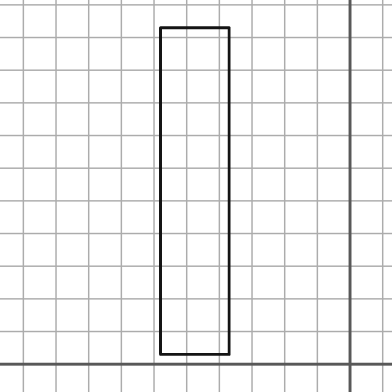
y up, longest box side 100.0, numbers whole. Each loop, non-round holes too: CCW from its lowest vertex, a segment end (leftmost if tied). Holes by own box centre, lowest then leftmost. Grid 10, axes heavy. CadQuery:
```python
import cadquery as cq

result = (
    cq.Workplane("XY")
    .moveTo(-58.0, 3.0)
    .lineTo(-37.0, 3.0)
    .lineTo(-37.0, 103.0)
    .lineTo(-58.0, 103.0)
    .close()
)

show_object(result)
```